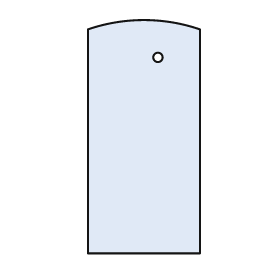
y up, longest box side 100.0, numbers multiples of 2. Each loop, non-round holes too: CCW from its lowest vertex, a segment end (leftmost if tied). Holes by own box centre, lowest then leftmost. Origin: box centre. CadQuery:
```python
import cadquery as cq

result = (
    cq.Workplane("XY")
    .moveTo(-24.0, -50.0)
    .lineTo(24.0, -50.0)
    .lineTo(24.0, 46.0)
    .threePointArc((0.0, 50.0), (-24.0, 46.0))
    .close()
    .moveTo(6.0, 34.0)
    .circle(2.0)
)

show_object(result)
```